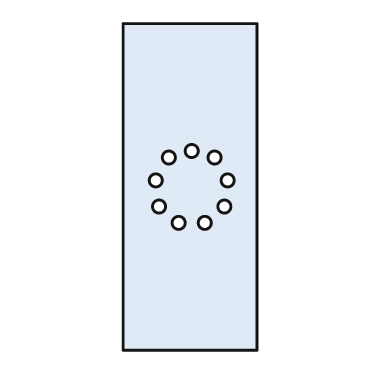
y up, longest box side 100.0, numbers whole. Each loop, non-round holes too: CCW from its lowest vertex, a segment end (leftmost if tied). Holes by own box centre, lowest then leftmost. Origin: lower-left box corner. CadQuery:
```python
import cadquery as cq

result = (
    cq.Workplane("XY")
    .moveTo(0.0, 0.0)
    .lineTo(41.0, 0.0)
    .lineTo(41.0, 100.0)
    .lineTo(0.0, 100.0)
    .close()
    .moveTo(17.0, 39.0)
    .circle(2.0)
    .moveTo(25.0, 39.0)
    .circle(2.0)
    .moveTo(11.0, 44.0)
    .circle(2.0)
    .moveTo(31.0, 44.0)
    .circle(2.0)
    .moveTo(10.0, 52.0)
    .circle(2.0)
    .moveTo(32.0, 52.0)
    .circle(2.0)
    .moveTo(14.0, 59.0)
    .circle(2.0)
    .moveTo(28.0, 59.0)
    .circle(2.0)
    .moveTo(21.0, 61.0)
    .circle(2.0)
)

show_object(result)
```